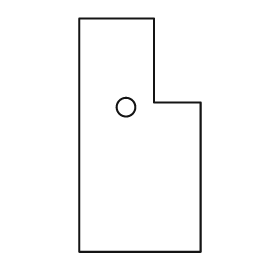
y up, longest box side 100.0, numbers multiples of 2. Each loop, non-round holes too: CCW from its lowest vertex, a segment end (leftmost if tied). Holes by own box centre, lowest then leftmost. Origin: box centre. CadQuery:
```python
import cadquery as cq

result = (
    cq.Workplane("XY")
    .moveTo(-26.0, -50.0)
    .lineTo(26.0, -50.0)
    .lineTo(26.0, 14.0)
    .lineTo(6.0, 14.0)
    .lineTo(6.0, 50.0)
    .lineTo(-26.0, 50.0)
    .close()
    .moveTo(-6.0, 12.0)
    .circle(4.0)
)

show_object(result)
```